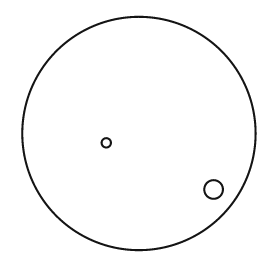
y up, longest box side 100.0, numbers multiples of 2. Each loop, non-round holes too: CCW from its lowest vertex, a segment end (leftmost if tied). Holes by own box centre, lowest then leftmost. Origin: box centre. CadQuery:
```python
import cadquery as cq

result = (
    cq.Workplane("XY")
    .moveTo(0.0, 0.0)
    .circle(50.0)
    .moveTo(32.0, -24.0)
    .circle(4.0)
    .moveTo(-14.0, -4.0)
    .circle(2.0)
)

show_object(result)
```